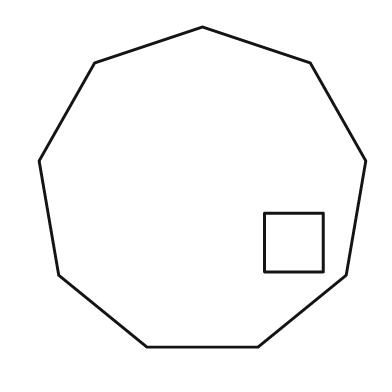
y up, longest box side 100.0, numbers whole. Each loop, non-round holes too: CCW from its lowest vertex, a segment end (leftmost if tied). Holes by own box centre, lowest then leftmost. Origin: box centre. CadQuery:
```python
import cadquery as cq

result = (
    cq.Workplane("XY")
    .moveTo(-17.0, -49.0)
    .lineTo(17.0, -49.0)
    .lineTo(44.0, -27.0)
    .lineTo(50.0, 8.0)
    .lineTo(33.0, 38.0)
    .lineTo(0.0, 49.0)
    .lineTo(-33.0, 38.0)
    .lineTo(-50.0, 8.0)
    .lineTo(-44.0, -27.0)
    .close()
    .moveTo(19.0, -26.0)
    .lineTo(37.0, -26.0)
    .lineTo(37.0, -8.0)
    .lineTo(19.0, -8.0)
    .close()
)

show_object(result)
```